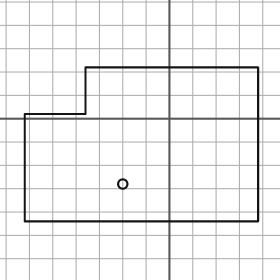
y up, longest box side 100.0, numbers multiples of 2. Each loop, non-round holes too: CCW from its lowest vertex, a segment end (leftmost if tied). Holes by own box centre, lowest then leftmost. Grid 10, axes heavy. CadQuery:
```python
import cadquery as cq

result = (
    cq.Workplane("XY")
    .moveTo(-62.0, -44.0)
    .lineTo(38.0, -44.0)
    .lineTo(38.0, 22.0)
    .lineTo(-36.0, 22.0)
    .lineTo(-36.0, 2.0)
    .lineTo(-62.0, 2.0)
    .close()
    .moveTo(-20.0, -28.0)
    .circle(2.0)
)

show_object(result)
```